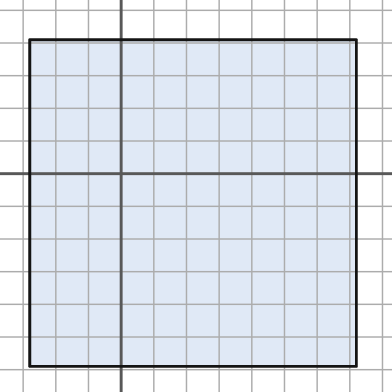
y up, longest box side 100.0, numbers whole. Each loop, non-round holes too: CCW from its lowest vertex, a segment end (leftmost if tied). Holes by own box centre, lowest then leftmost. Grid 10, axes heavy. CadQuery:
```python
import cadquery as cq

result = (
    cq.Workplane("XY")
    .moveTo(-28.0, -59.0)
    .lineTo(72.0, -59.0)
    .lineTo(72.0, 41.0)
    .lineTo(-28.0, 41.0)
    .close()
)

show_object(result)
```